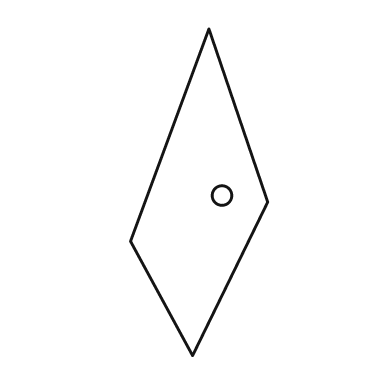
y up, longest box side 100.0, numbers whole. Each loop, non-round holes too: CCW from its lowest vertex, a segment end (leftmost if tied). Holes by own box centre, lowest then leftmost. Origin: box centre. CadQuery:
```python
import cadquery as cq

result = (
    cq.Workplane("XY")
    .moveTo(-2.0, -50.0)
    .lineTo(21.0, -3.0)
    .lineTo(3.0, 50.0)
    .lineTo(-21.0, -15.0)
    .close()
    .moveTo(7.0, -1.0)
    .circle(3.0)
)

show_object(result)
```